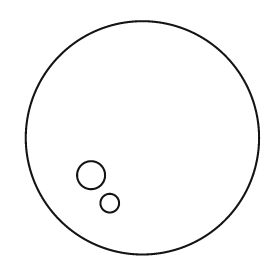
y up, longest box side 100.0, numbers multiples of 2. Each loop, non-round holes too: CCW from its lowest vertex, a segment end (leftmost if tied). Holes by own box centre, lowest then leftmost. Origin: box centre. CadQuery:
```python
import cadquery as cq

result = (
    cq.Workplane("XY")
    .moveTo(0.0, 0.0)
    .circle(50.0)
    .moveTo(-14.0, -28.0)
    .circle(4.0)
    .moveTo(-22.0, -16.0)
    .circle(6.0)
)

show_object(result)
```